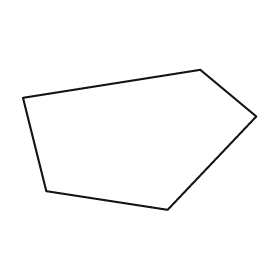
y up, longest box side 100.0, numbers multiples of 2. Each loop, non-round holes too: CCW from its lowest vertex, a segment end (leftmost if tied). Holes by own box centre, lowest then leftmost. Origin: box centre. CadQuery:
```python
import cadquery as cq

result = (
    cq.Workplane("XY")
    .moveTo(12.0, -30.0)
    .lineTo(50.0, 10.0)
    .lineTo(26.0, 30.0)
    .lineTo(-50.0, 18.0)
    .lineTo(-40.0, -22.0)
    .close()
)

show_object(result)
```